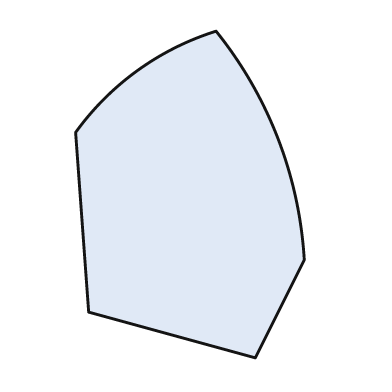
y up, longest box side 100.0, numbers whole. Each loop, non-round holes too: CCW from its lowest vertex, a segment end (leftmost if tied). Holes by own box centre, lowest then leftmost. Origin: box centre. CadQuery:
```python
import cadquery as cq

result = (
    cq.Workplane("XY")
    .moveTo(20.0, -50.0)
    .lineTo(35.0, -20.0)
    .threePointArc((27.0, 17.0), (8.0, 50.0))
    .threePointArc((-16.0, 38.0), (-35.0, 19.0))
    .lineTo(-31.0, -36.0)
    .close()
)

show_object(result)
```